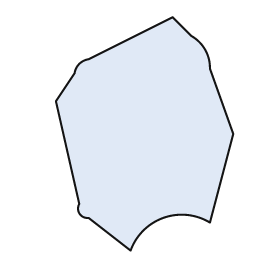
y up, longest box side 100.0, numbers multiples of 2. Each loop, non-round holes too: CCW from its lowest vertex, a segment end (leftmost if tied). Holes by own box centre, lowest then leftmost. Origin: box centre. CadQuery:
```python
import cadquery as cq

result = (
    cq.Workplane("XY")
    .moveTo(-6.0, -50.0)
    .threePointArc((8.0, -36.0), (28.0, -38.0))
    .lineTo(38.0, 0.0)
    .lineTo(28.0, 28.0)
    .threePointArc((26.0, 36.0), (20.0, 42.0))
    .lineTo(12.0, 50.0)
    .lineTo(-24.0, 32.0)
    .threePointArc((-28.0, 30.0), (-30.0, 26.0))
    .lineTo(-38.0, 14.0)
    .lineTo(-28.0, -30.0)
    .threePointArc((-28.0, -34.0), (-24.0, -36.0))
    .close()
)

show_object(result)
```